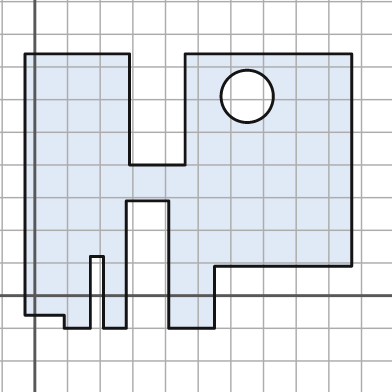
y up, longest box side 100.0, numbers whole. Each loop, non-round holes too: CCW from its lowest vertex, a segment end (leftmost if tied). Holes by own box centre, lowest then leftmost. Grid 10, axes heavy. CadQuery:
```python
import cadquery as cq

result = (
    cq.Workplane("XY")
    .moveTo(9.0, -10.0)
    .lineTo(17.0, -10.0)
    .lineTo(17.0, 12.0)
    .lineTo(21.0, 12.0)
    .lineTo(21.0, -10.0)
    .lineTo(28.0, -10.0)
    .lineTo(28.0, 29.0)
    .lineTo(41.0, 29.0)
    .lineTo(41.0, -10.0)
    .lineTo(55.0, -10.0)
    .lineTo(55.0, 9.0)
    .lineTo(97.0, 9.0)
    .lineTo(97.0, 74.0)
    .lineTo(46.0, 74.0)
    .lineTo(46.0, 40.0)
    .lineTo(29.0, 40.0)
    .lineTo(29.0, 74.0)
    .lineTo(-3.0, 74.0)
    .lineTo(-3.0, -6.0)
    .lineTo(9.0, -6.0)
    .close()
    .moveTo(65.0, 61.0)
    .circle(8.0)
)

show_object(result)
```